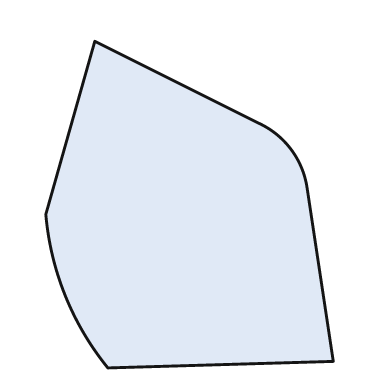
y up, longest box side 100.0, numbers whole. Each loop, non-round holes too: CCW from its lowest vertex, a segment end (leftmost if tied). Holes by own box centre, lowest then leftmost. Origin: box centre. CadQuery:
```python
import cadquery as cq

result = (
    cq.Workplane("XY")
    .moveTo(-25.0, -50.0)
    .lineTo(44.0, -48.0)
    .lineTo(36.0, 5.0)
    .threePointArc((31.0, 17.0), (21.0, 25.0))
    .lineTo(-29.0, 50.0)
    .lineTo(-44.0, -3.0)
    .threePointArc((-38.0, -28.0), (-25.0, -50.0))
    .close()
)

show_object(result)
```